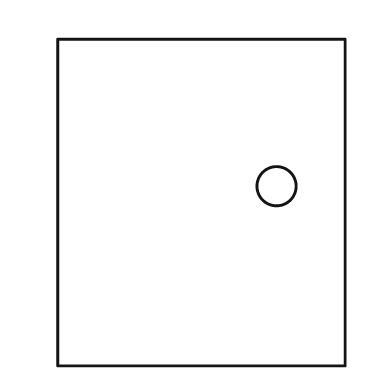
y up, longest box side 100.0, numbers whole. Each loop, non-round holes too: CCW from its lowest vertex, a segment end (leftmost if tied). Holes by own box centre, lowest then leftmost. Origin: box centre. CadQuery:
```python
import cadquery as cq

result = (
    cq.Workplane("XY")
    .moveTo(-44.0, -50.0)
    .lineTo(44.0, -50.0)
    .lineTo(44.0, 50.0)
    .lineTo(-44.0, 50.0)
    .close()
    .moveTo(23.0, 5.0)
    .circle(6.0)
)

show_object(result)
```